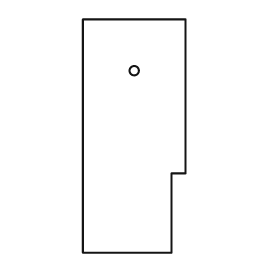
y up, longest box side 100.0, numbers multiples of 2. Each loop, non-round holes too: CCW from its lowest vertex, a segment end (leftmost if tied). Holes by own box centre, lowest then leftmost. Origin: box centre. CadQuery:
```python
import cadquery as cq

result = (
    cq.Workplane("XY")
    .moveTo(-22.0, -50.0)
    .lineTo(16.0, -50.0)
    .lineTo(16.0, -16.0)
    .lineTo(22.0, -16.0)
    .lineTo(22.0, 50.0)
    .lineTo(-22.0, 50.0)
    .close()
    .moveTo(0.0, 28.0)
    .circle(2.0)
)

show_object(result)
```